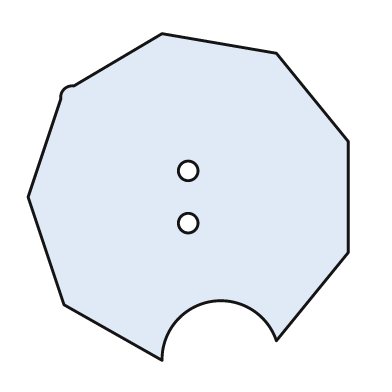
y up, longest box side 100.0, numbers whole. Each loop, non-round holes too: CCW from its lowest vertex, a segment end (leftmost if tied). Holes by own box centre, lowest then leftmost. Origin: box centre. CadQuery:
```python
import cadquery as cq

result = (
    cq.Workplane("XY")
    .moveTo(-8.0, -50.0)
    .threePointArc((7.0, -32.0), (27.0, -44.0))
    .lineTo(49.0, -17.0)
    .lineTo(49.0, 17.0)
    .lineTo(27.0, 44.0)
    .lineTo(-8.0, 50.0)
    .lineTo(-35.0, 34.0)
    .threePointArc((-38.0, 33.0), (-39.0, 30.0))
    .lineTo(-49.0, 0.0)
    .lineTo(-38.0, -33.0)
    .close()
    .moveTo(0.0, -8.0)
    .circle(3.0)
    .moveTo(0.0, 8.0)
    .circle(3.0)
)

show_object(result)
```